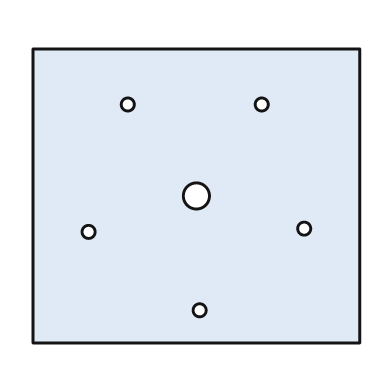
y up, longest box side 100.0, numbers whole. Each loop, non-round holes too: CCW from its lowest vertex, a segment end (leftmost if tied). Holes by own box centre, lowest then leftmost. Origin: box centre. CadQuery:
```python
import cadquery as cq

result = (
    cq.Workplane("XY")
    .moveTo(-50.0, -45.0)
    .lineTo(50.0, -45.0)
    .lineTo(50.0, 45.0)
    .lineTo(-50.0, 45.0)
    .close()
    .moveTo(1.0, -35.0)
    .circle(2.0)
    .moveTo(-33.0, -11.0)
    .circle(2.0)
    .moveTo(33.0, -10.0)
    .circle(2.0)
    .moveTo(0.0, 0.0)
    .circle(4.0)
    .moveTo(-21.0, 28.0)
    .circle(2.0)
    .moveTo(20.0, 28.0)
    .circle(2.0)
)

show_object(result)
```